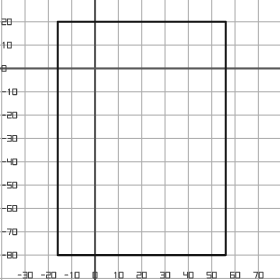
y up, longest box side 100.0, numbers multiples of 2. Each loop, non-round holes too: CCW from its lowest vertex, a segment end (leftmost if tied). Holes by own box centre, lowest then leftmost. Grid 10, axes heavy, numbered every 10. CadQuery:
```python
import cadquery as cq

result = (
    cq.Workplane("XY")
    .moveTo(-16.0, -80.0)
    .lineTo(56.0, -80.0)
    .lineTo(56.0, 20.0)
    .lineTo(-16.0, 20.0)
    .close()
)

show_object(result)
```